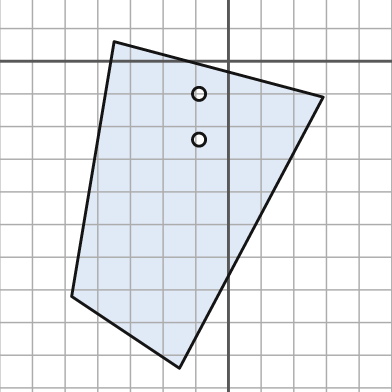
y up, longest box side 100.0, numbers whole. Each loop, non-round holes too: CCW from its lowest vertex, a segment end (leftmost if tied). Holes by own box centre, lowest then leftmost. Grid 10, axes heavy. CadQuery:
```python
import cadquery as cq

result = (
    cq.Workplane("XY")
    .moveTo(-15.0, -94.0)
    .lineTo(29.0, -11.0)
    .lineTo(-35.0, 6.0)
    .lineTo(-48.0, -72.0)
    .close()
    .moveTo(-9.0, -24.0)
    .circle(2.0)
    .moveTo(-9.0, -10.0)
    .circle(2.0)
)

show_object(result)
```